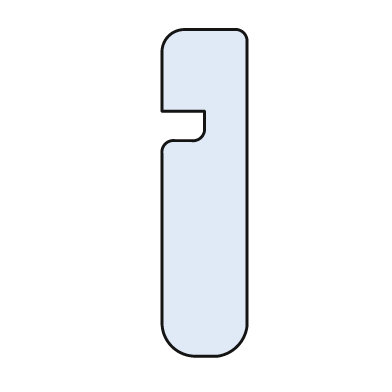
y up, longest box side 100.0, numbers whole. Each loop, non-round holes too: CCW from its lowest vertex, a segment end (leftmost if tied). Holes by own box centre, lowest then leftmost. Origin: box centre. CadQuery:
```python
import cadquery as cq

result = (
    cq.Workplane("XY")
    .moveTo(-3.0, -50.0)
    .lineTo(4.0, -50.0)
    .threePointArc((10.0, -47.0), (13.0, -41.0))
    .lineTo(13.0, 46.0)
    .threePointArc((12.0, 49.0), (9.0, 50.0))
    .lineTo(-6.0, 50.0)
    .threePointArc((-11.0, 48.0), (-13.0, 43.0))
    .lineTo(-13.0, 25.0)
    .lineTo(0.0, 25.0)
    .lineTo(0.0, 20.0)
    .threePointArc((-1.0, 17.0), (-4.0, 16.0))
    .lineTo(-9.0, 16.0)
    .threePointArc((-12.0, 15.0), (-13.0, 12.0))
    .lineTo(-13.0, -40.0)
    .threePointArc((-10.0, -47.0), (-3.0, -50.0))
    .close()
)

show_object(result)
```